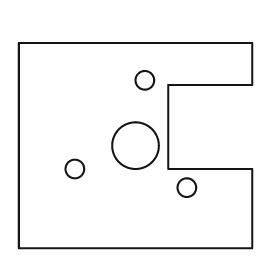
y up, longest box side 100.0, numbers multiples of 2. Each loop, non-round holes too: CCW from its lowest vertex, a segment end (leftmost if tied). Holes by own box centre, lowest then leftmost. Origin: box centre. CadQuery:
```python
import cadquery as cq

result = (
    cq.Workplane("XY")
    .moveTo(-50.0, -44.0)
    .lineTo(50.0, -44.0)
    .lineTo(50.0, -10.0)
    .lineTo(14.0, -10.0)
    .lineTo(14.0, 26.0)
    .lineTo(50.0, 26.0)
    .lineTo(50.0, 44.0)
    .lineTo(-50.0, 44.0)
    .close()
    .moveTo(22.0, -18.0)
    .circle(4.0)
    .moveTo(-26.0, -10.0)
    .circle(4.0)
    .moveTo(0.0, 0.0)
    .circle(10.0)
    .moveTo(4.0, 28.0)
    .circle(4.0)
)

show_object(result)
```